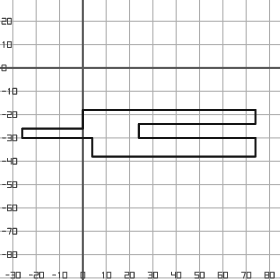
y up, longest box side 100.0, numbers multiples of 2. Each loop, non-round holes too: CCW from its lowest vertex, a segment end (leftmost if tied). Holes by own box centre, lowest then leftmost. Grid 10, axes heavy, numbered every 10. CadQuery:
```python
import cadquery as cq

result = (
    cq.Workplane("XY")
    .moveTo(4.0, -38.0)
    .lineTo(74.0, -38.0)
    .lineTo(74.0, -30.0)
    .lineTo(24.0, -30.0)
    .lineTo(24.0, -24.0)
    .lineTo(74.0, -24.0)
    .lineTo(74.0, -18.0)
    .lineTo(0.0, -18.0)
    .lineTo(0.0, -26.0)
    .lineTo(-26.0, -26.0)
    .lineTo(-26.0, -30.0)
    .lineTo(4.0, -30.0)
    .close()
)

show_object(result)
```